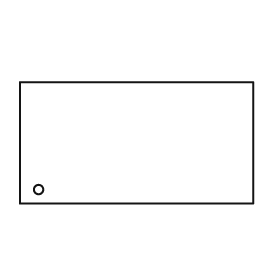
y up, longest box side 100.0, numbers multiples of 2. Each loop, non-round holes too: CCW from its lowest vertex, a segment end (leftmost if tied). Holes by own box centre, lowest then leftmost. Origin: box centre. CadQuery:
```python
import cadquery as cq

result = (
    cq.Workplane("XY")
    .moveTo(-50.0, -26.0)
    .lineTo(50.0, -26.0)
    .lineTo(50.0, 26.0)
    .lineTo(-50.0, 26.0)
    .close()
    .moveTo(-42.0, -20.0)
    .circle(2.0)
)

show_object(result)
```